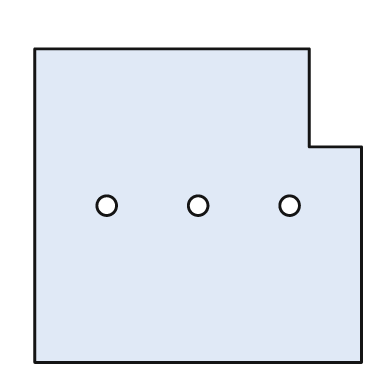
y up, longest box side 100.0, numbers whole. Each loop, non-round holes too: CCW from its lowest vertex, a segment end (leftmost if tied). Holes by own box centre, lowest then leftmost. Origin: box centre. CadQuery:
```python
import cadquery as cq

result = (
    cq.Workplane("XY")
    .moveTo(-50.0, -48.0)
    .lineTo(50.0, -48.0)
    .lineTo(50.0, 18.0)
    .lineTo(34.0, 18.0)
    .lineTo(34.0, 48.0)
    .lineTo(-50.0, 48.0)
    .close()
    .moveTo(-28.0, 0.0)
    .circle(3.0)
    .moveTo(0.0, 0.0)
    .circle(3.0)
    .moveTo(28.0, 0.0)
    .circle(3.0)
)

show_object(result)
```